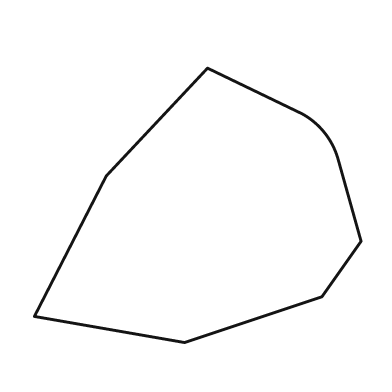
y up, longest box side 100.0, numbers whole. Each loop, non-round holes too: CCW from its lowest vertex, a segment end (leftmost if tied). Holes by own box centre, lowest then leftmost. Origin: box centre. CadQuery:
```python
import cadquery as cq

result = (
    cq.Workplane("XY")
    .moveTo(-4.0, -42.0)
    .lineTo(38.0, -28.0)
    .lineTo(50.0, -11.0)
    .lineTo(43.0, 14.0)
    .threePointArc((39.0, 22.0), (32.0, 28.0))
    .lineTo(3.0, 42.0)
    .lineTo(-28.0, 9.0)
    .lineTo(-50.0, -34.0)
    .close()
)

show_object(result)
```